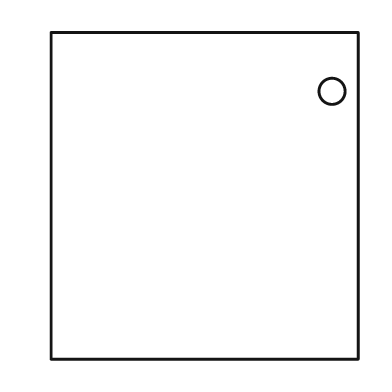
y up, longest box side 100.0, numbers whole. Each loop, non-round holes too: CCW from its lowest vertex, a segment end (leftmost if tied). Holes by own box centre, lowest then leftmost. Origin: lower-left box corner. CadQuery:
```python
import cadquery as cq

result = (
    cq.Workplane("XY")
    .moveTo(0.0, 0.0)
    .lineTo(94.0, 0.0)
    .lineTo(94.0, 100.0)
    .lineTo(0.0, 100.0)
    .close()
    .moveTo(86.0, 82.0)
    .circle(4.0)
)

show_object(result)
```